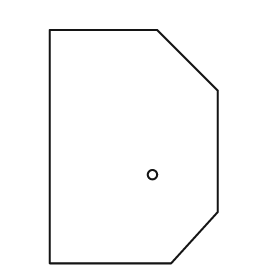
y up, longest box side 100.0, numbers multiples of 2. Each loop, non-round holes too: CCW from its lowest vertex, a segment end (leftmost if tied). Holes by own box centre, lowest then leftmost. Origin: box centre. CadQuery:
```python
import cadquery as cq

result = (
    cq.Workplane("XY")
    .moveTo(-36.0, -50.0)
    .lineTo(16.0, -50.0)
    .lineTo(36.0, -28.0)
    .lineTo(36.0, 24.0)
    .lineTo(10.0, 50.0)
    .lineTo(-36.0, 50.0)
    .close()
    .moveTo(8.0, -12.0)
    .circle(2.0)
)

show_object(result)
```